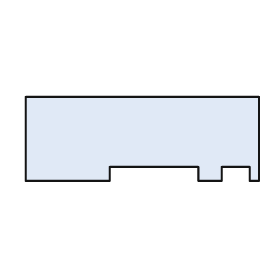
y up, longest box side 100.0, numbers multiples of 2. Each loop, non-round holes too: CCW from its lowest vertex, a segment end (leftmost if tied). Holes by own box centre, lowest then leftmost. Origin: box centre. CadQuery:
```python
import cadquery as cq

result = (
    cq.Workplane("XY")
    .moveTo(-50.0, -18.0)
    .lineTo(-14.0, -18.0)
    .lineTo(-14.0, -12.0)
    .lineTo(24.0, -12.0)
    .lineTo(24.0, -18.0)
    .lineTo(34.0, -18.0)
    .lineTo(34.0, -12.0)
    .lineTo(46.0, -12.0)
    .lineTo(46.0, -18.0)
    .lineTo(50.0, -18.0)
    .lineTo(50.0, 18.0)
    .lineTo(-50.0, 18.0)
    .close()
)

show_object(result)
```